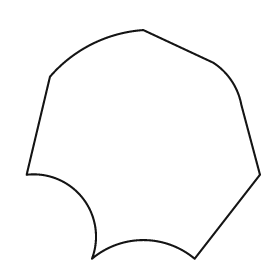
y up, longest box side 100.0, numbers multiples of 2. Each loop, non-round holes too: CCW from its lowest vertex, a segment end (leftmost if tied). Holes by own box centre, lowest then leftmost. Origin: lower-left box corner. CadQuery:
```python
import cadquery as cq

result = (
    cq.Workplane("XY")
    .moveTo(28.0, 0.0)
    .threePointArc((50.0, 8.0), (72.0, 0.0))
    .lineTo(100.0, 36.0)
    .lineTo(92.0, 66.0)
    .threePointArc((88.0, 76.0), (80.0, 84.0))
    .lineTo(50.0, 98.0)
    .threePointArc((28.0, 92.0), (10.0, 78.0))
    .lineTo(0.0, 36.0)
    .threePointArc((24.0, 26.0), (28.0, 0.0))
    .close()
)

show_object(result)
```